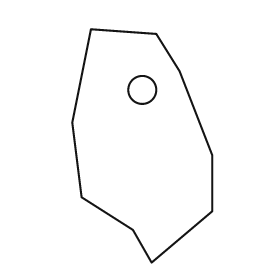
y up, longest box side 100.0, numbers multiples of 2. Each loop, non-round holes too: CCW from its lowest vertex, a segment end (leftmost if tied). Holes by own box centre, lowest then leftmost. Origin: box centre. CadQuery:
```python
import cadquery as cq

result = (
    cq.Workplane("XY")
    .moveTo(4.0, -50.0)
    .lineTo(30.0, -28.0)
    .lineTo(30.0, -4.0)
    .lineTo(16.0, 32.0)
    .lineTo(6.0, 48.0)
    .lineTo(-22.0, 50.0)
    .lineTo(-30.0, 10.0)
    .lineTo(-26.0, -22.0)
    .lineTo(-4.0, -36.0)
    .close()
    .moveTo(0.0, 24.0)
    .circle(6.0)
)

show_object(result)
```